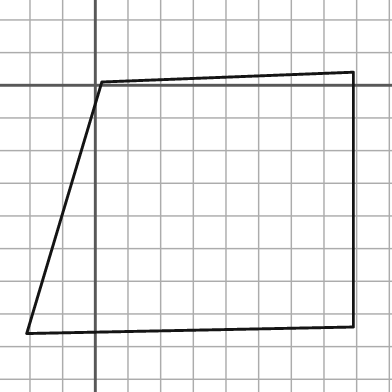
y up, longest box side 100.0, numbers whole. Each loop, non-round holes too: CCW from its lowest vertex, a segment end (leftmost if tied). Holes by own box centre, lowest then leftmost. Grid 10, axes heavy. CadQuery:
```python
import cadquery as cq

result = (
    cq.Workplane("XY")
    .moveTo(-21.0, -76.0)
    .lineTo(79.0, -74.0)
    .lineTo(79.0, 4.0)
    .lineTo(2.0, 1.0)
    .close()
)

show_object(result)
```